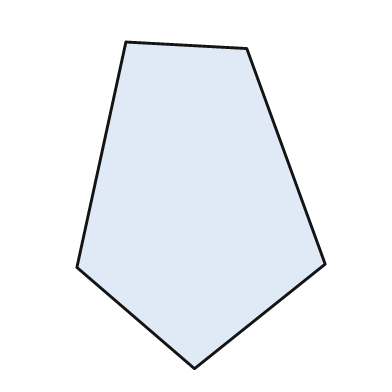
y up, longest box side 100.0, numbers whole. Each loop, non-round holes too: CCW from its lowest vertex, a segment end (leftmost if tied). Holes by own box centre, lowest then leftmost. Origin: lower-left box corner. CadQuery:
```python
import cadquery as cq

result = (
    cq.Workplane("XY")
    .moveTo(36.0, 0.0)
    .lineTo(76.0, 32.0)
    .lineTo(52.0, 98.0)
    .lineTo(15.0, 100.0)
    .lineTo(0.0, 31.0)
    .close()
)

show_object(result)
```